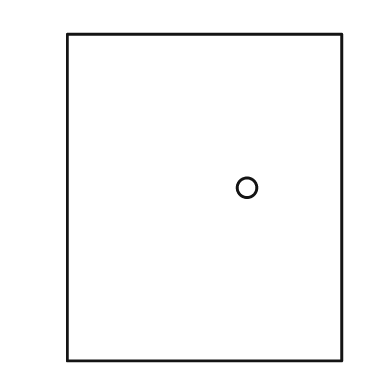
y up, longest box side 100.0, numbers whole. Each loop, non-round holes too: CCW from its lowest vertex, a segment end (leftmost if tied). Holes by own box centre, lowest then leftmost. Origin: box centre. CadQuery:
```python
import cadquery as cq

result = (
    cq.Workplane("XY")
    .moveTo(-42.0, -50.0)
    .lineTo(42.0, -50.0)
    .lineTo(42.0, 50.0)
    .lineTo(-42.0, 50.0)
    .close()
    .moveTo(13.0, 3.0)
    .circle(3.0)
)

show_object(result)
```